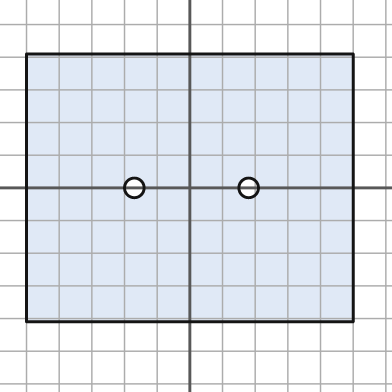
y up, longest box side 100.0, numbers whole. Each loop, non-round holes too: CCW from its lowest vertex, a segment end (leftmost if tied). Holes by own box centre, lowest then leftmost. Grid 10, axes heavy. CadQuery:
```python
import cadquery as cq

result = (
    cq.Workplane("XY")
    .moveTo(-50.0, -41.0)
    .lineTo(50.0, -41.0)
    .lineTo(50.0, 41.0)
    .lineTo(-50.0, 41.0)
    .close()
    .moveTo(-17.0, 0.0)
    .circle(3.0)
    .moveTo(18.0, 0.0)
    .circle(3.0)
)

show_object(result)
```